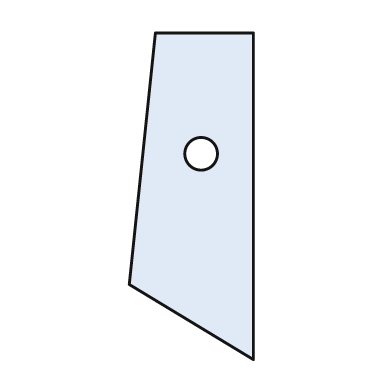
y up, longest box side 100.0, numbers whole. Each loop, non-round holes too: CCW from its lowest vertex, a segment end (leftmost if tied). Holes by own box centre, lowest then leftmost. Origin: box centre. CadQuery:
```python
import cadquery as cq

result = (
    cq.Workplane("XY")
    .moveTo(19.0, -50.0)
    .lineTo(19.0, 50.0)
    .lineTo(-11.0, 50.0)
    .lineTo(-19.0, -27.0)
    .close()
    .moveTo(3.0, 13.0)
    .circle(5.0)
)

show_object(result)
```